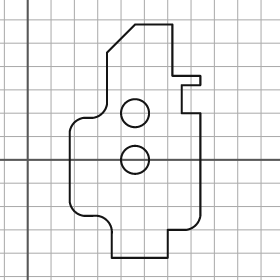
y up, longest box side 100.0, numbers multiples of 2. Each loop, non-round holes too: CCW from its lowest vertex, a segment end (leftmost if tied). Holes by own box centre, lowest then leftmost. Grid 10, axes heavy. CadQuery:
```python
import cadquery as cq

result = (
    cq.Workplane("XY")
    .moveTo(36.0, -42.0)
    .lineTo(60.0, -42.0)
    .lineTo(60.0, -30.0)
    .lineTo(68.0, -30.0)
    .threePointArc((72.0, -28.0), (74.0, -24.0))
    .lineTo(74.0, 20.0)
    .lineTo(66.0, 20.0)
    .lineTo(66.0, 32.0)
    .lineTo(74.0, 32.0)
    .lineTo(74.0, 36.0)
    .lineTo(62.0, 36.0)
    .lineTo(62.0, 58.0)
    .lineTo(46.0, 58.0)
    .lineTo(34.0, 46.0)
    .lineTo(34.0, 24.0)
    .threePointArc((32.0, 20.0), (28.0, 18.0))
    .lineTo(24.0, 18.0)
    .threePointArc((20.0, 16.0), (18.0, 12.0))
    .lineTo(18.0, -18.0)
    .threePointArc((20.0, -22.0), (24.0, -24.0))
    .lineTo(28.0, -24.0)
    .threePointArc((34.0, -26.0), (36.0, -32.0))
    .close()
    .moveTo(46.0, 0.0)
    .circle(6.0)
    .moveTo(46.0, 20.0)
    .circle(6.0)
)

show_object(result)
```